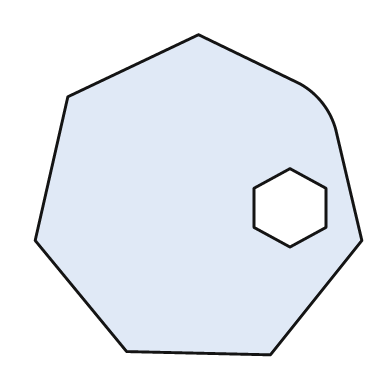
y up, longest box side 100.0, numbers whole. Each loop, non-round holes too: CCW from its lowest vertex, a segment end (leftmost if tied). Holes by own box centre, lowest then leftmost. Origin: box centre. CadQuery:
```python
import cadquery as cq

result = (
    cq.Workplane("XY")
    .moveTo(22.0, -49.0)
    .lineTo(50.0, -14.0)
    .lineTo(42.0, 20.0)
    .threePointArc((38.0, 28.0), (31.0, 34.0))
    .lineTo(0.0, 49.0)
    .lineTo(-40.0, 30.0)
    .lineTo(-50.0, -14.0)
    .lineTo(-22.0, -48.0)
    .close()
    .moveTo(28.0, -16.0)
    .lineTo(39.0, -10.0)
    .lineTo(39.0, 2.0)
    .lineTo(28.0, 8.0)
    .lineTo(17.0, 2.0)
    .lineTo(17.0, -10.0)
    .close()
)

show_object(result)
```